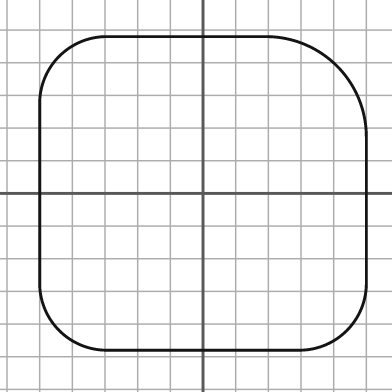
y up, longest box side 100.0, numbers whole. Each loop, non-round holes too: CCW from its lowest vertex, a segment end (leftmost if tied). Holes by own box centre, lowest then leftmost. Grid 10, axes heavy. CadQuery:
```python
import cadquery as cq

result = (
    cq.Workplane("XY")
    .moveTo(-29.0, -48.0)
    .lineTo(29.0, -48.0)
    .threePointArc((44.0, -42.0), (50.0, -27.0))
    .lineTo(50.0, 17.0)
    .threePointArc((41.0, 39.0), (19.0, 48.0))
    .lineTo(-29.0, 48.0)
    .threePointArc((-44.0, 42.0), (-50.0, 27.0))
    .lineTo(-50.0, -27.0)
    .threePointArc((-44.0, -42.0), (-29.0, -48.0))
    .close()
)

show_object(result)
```